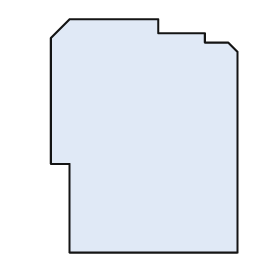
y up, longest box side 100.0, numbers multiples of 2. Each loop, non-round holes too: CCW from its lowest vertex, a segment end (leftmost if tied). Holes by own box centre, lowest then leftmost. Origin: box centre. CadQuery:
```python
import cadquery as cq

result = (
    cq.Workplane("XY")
    .moveTo(-32.0, -50.0)
    .lineTo(40.0, -50.0)
    .lineTo(40.0, 36.0)
    .lineTo(36.0, 40.0)
    .lineTo(26.0, 40.0)
    .lineTo(26.0, 44.0)
    .lineTo(6.0, 44.0)
    .lineTo(6.0, 50.0)
    .lineTo(-32.0, 50.0)
    .lineTo(-40.0, 42.0)
    .lineTo(-40.0, -12.0)
    .lineTo(-32.0, -12.0)
    .close()
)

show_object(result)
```